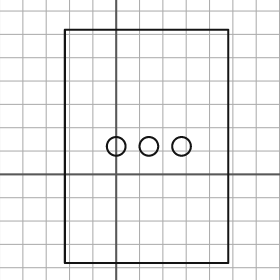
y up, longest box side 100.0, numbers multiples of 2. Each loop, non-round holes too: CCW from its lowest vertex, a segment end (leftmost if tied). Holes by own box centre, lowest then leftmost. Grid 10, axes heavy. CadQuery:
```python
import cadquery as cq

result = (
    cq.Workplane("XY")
    .moveTo(-22.0, -38.0)
    .lineTo(48.0, -38.0)
    .lineTo(48.0, 62.0)
    .lineTo(-22.0, 62.0)
    .close()
    .moveTo(0.0, 12.0)
    .circle(4.0)
    .moveTo(14.0, 12.0)
    .circle(4.0)
    .moveTo(28.0, 12.0)
    .circle(4.0)
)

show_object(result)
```